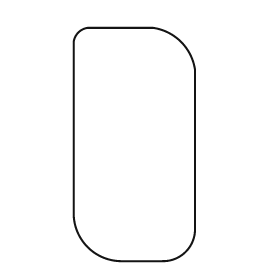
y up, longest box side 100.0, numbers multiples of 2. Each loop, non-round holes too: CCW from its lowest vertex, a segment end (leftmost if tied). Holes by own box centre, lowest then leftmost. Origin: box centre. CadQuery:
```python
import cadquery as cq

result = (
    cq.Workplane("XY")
    .moveTo(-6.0, -50.0)
    .lineTo(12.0, -50.0)
    .threePointArc((22.0, -46.0), (26.0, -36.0))
    .lineTo(26.0, 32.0)
    .threePointArc((20.0, 44.0), (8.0, 50.0))
    .lineTo(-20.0, 50.0)
    .threePointArc((-24.0, 48.0), (-26.0, 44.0))
    .lineTo(-26.0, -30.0)
    .threePointArc((-20.0, -44.0), (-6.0, -50.0))
    .close()
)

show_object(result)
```